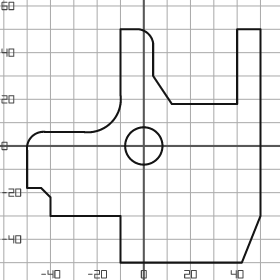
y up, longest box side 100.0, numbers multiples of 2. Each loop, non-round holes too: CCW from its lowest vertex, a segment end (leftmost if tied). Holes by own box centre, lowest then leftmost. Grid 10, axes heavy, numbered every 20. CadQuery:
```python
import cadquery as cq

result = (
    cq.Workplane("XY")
    .moveTo(-10.0, -50.0)
    .lineTo(42.0, -50.0)
    .lineTo(50.0, -30.0)
    .lineTo(50.0, 50.0)
    .lineTo(40.0, 50.0)
    .lineTo(40.0, 18.0)
    .lineTo(12.0, 18.0)
    .lineTo(4.0, 30.0)
    .lineTo(4.0, 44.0)
    .threePointArc((2.0, 48.0), (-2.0, 50.0))
    .lineTo(-10.0, 50.0)
    .lineTo(-10.0, 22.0)
    .threePointArc((-14.0, 10.0), (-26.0, 6.0))
    .lineTo(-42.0, 6.0)
    .threePointArc((-48.0, 4.0), (-50.0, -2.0))
    .lineTo(-50.0, -18.0)
    .lineTo(-44.0, -18.0)
    .lineTo(-40.0, -22.0)
    .lineTo(-40.0, -30.0)
    .lineTo(-10.0, -30.0)
    .close()
    .moveTo(0.0, 0.0)
    .circle(8.0)
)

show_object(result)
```